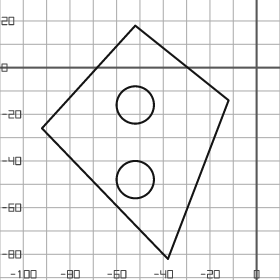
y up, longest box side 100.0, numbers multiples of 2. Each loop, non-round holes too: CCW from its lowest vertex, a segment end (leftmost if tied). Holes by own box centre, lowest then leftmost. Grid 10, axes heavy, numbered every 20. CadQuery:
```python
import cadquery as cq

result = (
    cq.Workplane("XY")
    .moveTo(-38.0, -82.0)
    .lineTo(-12.0, -14.0)
    .lineTo(-52.0, 18.0)
    .lineTo(-92.0, -26.0)
    .close()
    .moveTo(-52.0, -48.0)
    .circle(8.0)
    .moveTo(-52.0, -16.0)
    .circle(8.0)
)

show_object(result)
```